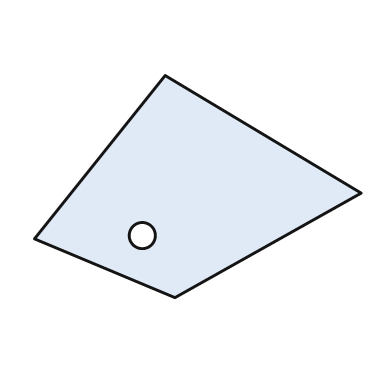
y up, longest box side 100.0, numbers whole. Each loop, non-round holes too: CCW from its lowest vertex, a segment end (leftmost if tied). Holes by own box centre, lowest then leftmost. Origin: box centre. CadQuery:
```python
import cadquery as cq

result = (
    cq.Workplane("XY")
    .moveTo(-7.0, -34.0)
    .lineTo(50.0, -2.0)
    .lineTo(-10.0, 34.0)
    .lineTo(-50.0, -16.0)
    .close()
    .moveTo(-17.0, -15.0)
    .circle(4.0)
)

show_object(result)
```